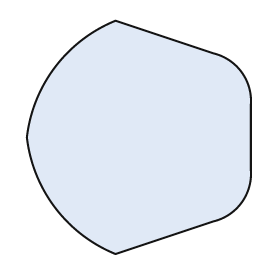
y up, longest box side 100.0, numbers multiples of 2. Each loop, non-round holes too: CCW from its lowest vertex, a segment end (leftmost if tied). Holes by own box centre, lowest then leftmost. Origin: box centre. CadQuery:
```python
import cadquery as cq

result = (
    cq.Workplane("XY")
    .moveTo(-10.0, -50.0)
    .lineTo(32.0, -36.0)
    .threePointArc((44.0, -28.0), (48.0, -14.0))
    .lineTo(48.0, 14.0)
    .threePointArc((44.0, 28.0), (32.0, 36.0))
    .lineTo(-10.0, 50.0)
    .threePointArc((-36.0, 30.0), (-48.0, 0.0))
    .threePointArc((-36.0, -30.0), (-10.0, -50.0))
    .close()
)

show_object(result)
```